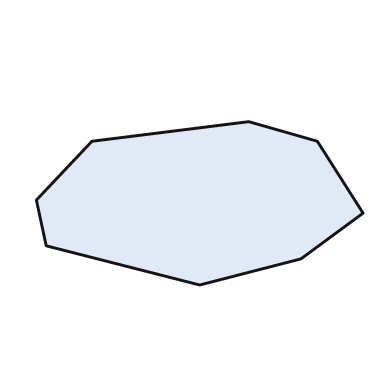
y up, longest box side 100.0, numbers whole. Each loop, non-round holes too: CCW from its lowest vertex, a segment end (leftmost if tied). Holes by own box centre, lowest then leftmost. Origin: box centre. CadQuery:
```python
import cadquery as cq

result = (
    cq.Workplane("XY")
    .moveTo(0.0, -25.0)
    .lineTo(31.0, -17.0)
    .lineTo(50.0, -3.0)
    .lineTo(36.0, 19.0)
    .lineTo(15.0, 25.0)
    .lineTo(-33.0, 19.0)
    .lineTo(-50.0, 1.0)
    .lineTo(-47.0, -13.0)
    .close()
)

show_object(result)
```